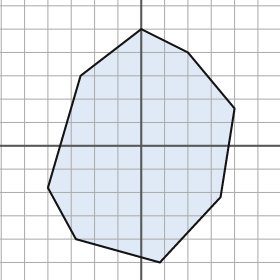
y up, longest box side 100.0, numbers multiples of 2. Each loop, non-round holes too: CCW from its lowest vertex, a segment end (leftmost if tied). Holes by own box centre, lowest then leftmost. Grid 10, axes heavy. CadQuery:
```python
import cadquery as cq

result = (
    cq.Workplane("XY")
    .moveTo(8.0, -50.0)
    .lineTo(34.0, -22.0)
    .lineTo(40.0, 16.0)
    .lineTo(20.0, 40.0)
    .lineTo(0.0, 50.0)
    .lineTo(-26.0, 30.0)
    .lineTo(-40.0, -18.0)
    .lineTo(-28.0, -40.0)
    .close()
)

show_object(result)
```